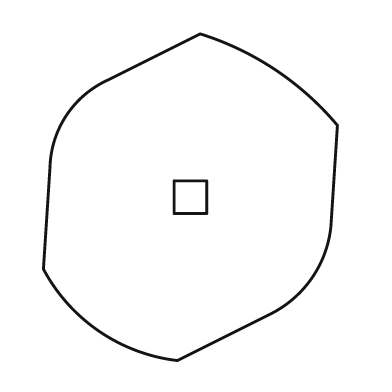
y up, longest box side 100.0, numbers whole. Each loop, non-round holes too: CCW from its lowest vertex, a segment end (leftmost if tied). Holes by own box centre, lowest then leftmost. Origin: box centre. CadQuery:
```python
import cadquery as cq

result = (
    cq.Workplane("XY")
    .moveTo(-4.0, -50.0)
    .lineTo(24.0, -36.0)
    .threePointArc((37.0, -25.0), (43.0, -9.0))
    .lineTo(45.0, 22.0)
    .threePointArc((26.0, 39.0), (3.0, 50.0))
    .lineTo(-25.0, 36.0)
    .threePointArc((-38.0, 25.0), (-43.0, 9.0))
    .lineTo(-45.0, -22.0)
    .threePointArc((-28.0, -41.0), (-4.0, -50.0))
    .close()
    .moveTo(-5.0, -5.0)
    .lineTo(5.0, -5.0)
    .lineTo(5.0, 5.0)
    .lineTo(-5.0, 5.0)
    .close()
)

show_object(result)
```